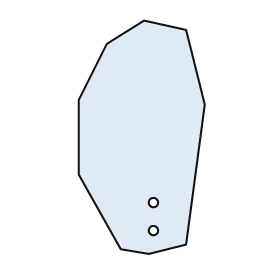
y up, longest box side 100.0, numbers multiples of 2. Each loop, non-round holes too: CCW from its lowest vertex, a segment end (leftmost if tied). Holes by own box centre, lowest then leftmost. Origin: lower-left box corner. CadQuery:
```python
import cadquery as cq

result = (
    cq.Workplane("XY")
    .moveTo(30.0, 0.0)
    .lineTo(46.0, 4.0)
    .lineTo(54.0, 64.0)
    .lineTo(46.0, 96.0)
    .lineTo(28.0, 100.0)
    .lineTo(12.0, 90.0)
    .lineTo(0.0, 66.0)
    .lineTo(0.0, 34.0)
    .lineTo(18.0, 2.0)
    .close()
    .moveTo(32.0, 10.0)
    .circle(2.0)
    .moveTo(32.0, 22.0)
    .circle(2.0)
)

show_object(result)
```